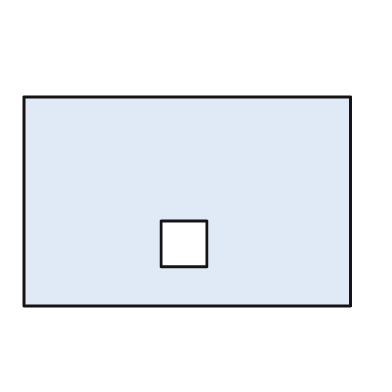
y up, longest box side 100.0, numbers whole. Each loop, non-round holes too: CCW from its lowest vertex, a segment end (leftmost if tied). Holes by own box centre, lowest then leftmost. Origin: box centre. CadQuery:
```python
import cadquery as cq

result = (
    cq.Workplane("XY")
    .moveTo(-50.0, -32.0)
    .lineTo(50.0, -32.0)
    .lineTo(50.0, 32.0)
    .lineTo(-50.0, 32.0)
    .close()
    .moveTo(-8.0, -20.0)
    .lineTo(6.0, -20.0)
    .lineTo(6.0, -6.0)
    .lineTo(-8.0, -6.0)
    .close()
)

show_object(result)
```